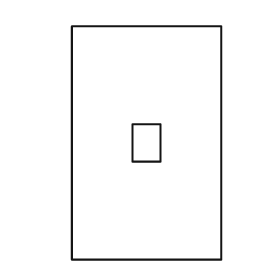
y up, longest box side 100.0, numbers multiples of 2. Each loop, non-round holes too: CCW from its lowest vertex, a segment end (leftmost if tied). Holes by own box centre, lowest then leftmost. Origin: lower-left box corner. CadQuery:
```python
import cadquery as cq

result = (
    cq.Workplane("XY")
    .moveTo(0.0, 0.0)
    .lineTo(64.0, 0.0)
    .lineTo(64.0, 100.0)
    .lineTo(0.0, 100.0)
    .close()
    .moveTo(26.0, 42.0)
    .lineTo(38.0, 42.0)
    .lineTo(38.0, 58.0)
    .lineTo(26.0, 58.0)
    .close()
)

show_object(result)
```